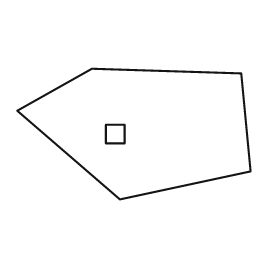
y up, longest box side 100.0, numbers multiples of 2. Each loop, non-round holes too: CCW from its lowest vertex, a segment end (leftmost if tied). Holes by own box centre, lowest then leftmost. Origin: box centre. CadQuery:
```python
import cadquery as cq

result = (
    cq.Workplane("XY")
    .moveTo(-6.0, -28.0)
    .lineTo(50.0, -16.0)
    .lineTo(46.0, 26.0)
    .lineTo(-18.0, 28.0)
    .lineTo(-50.0, 10.0)
    .close()
    .moveTo(-12.0, -4.0)
    .lineTo(-4.0, -4.0)
    .lineTo(-4.0, 4.0)
    .lineTo(-12.0, 4.0)
    .close()
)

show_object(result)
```